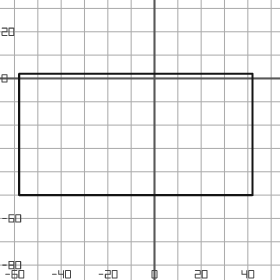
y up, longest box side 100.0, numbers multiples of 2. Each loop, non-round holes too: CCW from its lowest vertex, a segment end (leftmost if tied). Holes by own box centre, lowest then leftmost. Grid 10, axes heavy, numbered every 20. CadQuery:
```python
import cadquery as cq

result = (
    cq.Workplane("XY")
    .moveTo(-58.0, -50.0)
    .lineTo(42.0, -50.0)
    .lineTo(42.0, 2.0)
    .lineTo(-58.0, 2.0)
    .close()
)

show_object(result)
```